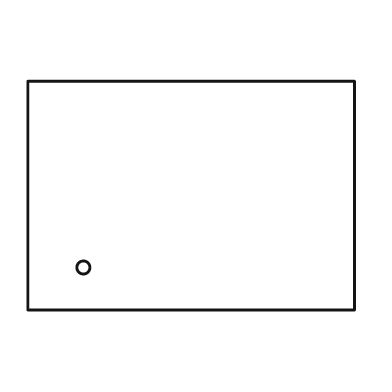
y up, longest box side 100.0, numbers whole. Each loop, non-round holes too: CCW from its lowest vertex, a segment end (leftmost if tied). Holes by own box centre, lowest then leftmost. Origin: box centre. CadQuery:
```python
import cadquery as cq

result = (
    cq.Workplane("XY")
    .moveTo(-50.0, -35.0)
    .lineTo(50.0, -35.0)
    .lineTo(50.0, 35.0)
    .lineTo(-50.0, 35.0)
    .close()
    .moveTo(-33.0, -22.0)
    .circle(2.0)
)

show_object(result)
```